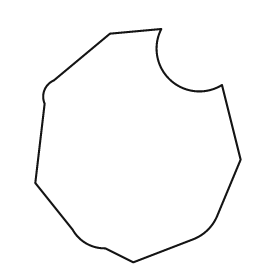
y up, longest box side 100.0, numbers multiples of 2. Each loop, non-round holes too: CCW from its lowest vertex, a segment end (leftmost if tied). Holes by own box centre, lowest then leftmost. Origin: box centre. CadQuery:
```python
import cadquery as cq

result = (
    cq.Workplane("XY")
    .moveTo(-2.0, -50.0)
    .lineTo(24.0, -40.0)
    .threePointArc((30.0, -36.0), (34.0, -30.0))
    .lineTo(44.0, -6.0)
    .lineTo(36.0, 26.0)
    .threePointArc((14.0, 28.0), (10.0, 50.0))
    .lineTo(-12.0, 48.0)
    .lineTo(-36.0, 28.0)
    .threePointArc((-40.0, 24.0), (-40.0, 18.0))
    .lineTo(-44.0, -16.0)
    .lineTo(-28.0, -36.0)
    .threePointArc((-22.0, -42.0), (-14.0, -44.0))
    .close()
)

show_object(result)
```